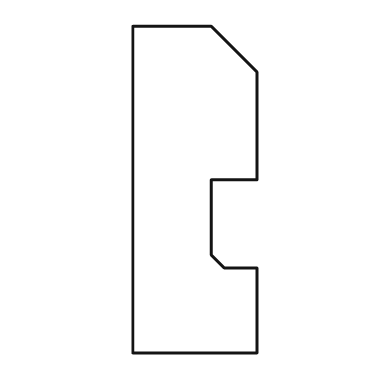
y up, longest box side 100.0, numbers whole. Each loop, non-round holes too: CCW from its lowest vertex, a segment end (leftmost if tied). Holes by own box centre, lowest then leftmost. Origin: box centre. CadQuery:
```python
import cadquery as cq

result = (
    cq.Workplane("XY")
    .moveTo(-19.0, -50.0)
    .lineTo(19.0, -50.0)
    .lineTo(19.0, -24.0)
    .lineTo(9.0, -24.0)
    .lineTo(5.0, -20.0)
    .lineTo(5.0, 3.0)
    .lineTo(19.0, 3.0)
    .lineTo(19.0, 36.0)
    .lineTo(5.0, 50.0)
    .lineTo(-19.0, 50.0)
    .close()
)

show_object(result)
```